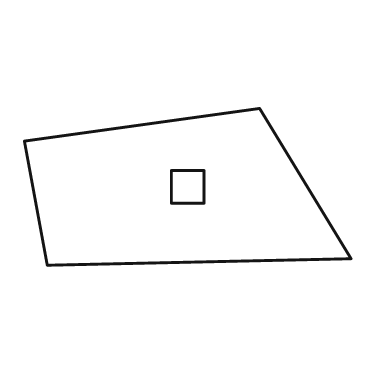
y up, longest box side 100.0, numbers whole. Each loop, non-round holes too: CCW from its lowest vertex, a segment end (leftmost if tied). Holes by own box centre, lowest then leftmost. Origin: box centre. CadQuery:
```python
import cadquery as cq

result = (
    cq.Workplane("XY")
    .moveTo(-43.0, -24.0)
    .lineTo(50.0, -22.0)
    .lineTo(22.0, 24.0)
    .lineTo(-50.0, 14.0)
    .close()
    .moveTo(-5.0, -5.0)
    .lineTo(5.0, -5.0)
    .lineTo(5.0, 5.0)
    .lineTo(-5.0, 5.0)
    .close()
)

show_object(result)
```